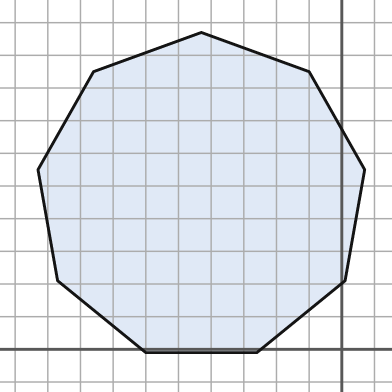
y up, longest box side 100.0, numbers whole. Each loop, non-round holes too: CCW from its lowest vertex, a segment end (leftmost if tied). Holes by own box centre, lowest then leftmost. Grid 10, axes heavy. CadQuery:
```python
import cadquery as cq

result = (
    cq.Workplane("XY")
    .moveTo(-60.0, -1.0)
    .lineTo(-26.0, -1.0)
    .lineTo(1.0, 21.0)
    .lineTo(7.0, 55.0)
    .lineTo(-10.0, 85.0)
    .lineTo(-43.0, 97.0)
    .lineTo(-76.0, 85.0)
    .lineTo(-93.0, 55.0)
    .lineTo(-87.0, 21.0)
    .close()
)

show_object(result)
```